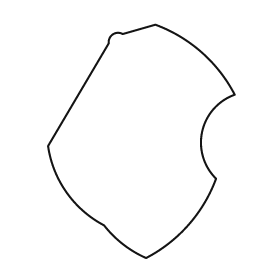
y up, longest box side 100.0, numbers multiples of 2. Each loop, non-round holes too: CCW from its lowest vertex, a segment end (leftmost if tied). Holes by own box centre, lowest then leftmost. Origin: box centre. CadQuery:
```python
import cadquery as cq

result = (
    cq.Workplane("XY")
    .moveTo(2.0, -50.0)
    .threePointArc((20.0, -36.0), (32.0, -16.0))
    .threePointArc((26.0, 4.0), (40.0, 20.0))
    .threePointArc((26.0, 38.0), (6.0, 50.0))
    .lineTo(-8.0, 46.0)
    .threePointArc((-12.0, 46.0), (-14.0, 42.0))
    .lineTo(-40.0, -2.0)
    .threePointArc((-32.0, -22.0), (-16.0, -36.0))
    .threePointArc((-8.0, -44.0), (2.0, -50.0))
    .close()
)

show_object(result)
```